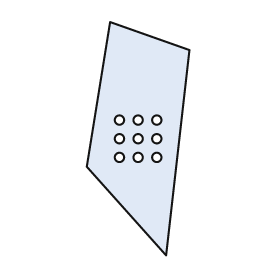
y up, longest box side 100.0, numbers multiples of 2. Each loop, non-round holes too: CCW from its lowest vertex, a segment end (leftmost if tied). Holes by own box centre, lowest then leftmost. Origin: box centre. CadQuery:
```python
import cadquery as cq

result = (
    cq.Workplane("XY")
    .moveTo(12.0, -50.0)
    .lineTo(22.0, 38.0)
    .lineTo(-12.0, 50.0)
    .lineTo(-22.0, -12.0)
    .close()
    .moveTo(-8.0, -8.0)
    .circle(2.0)
    .moveTo(0.0, -8.0)
    .circle(2.0)
    .moveTo(8.0, -8.0)
    .circle(2.0)
    .moveTo(-8.0, 0.0)
    .circle(2.0)
    .moveTo(0.0, 0.0)
    .circle(2.0)
    .moveTo(8.0, 0.0)
    .circle(2.0)
    .moveTo(-8.0, 8.0)
    .circle(2.0)
    .moveTo(0.0, 8.0)
    .circle(2.0)
    .moveTo(8.0, 8.0)
    .circle(2.0)
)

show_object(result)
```